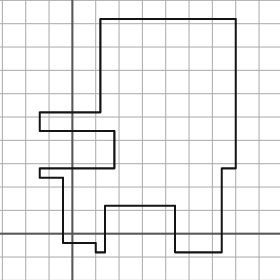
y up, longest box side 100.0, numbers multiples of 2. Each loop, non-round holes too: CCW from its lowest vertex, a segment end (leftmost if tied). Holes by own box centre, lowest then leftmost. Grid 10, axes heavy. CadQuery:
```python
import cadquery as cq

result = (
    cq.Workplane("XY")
    .moveTo(10.0, -8.0)
    .lineTo(14.0, -8.0)
    .lineTo(14.0, 12.0)
    .lineTo(44.0, 12.0)
    .lineTo(44.0, -8.0)
    .lineTo(64.0, -8.0)
    .lineTo(64.0, 28.0)
    .lineTo(70.0, 28.0)
    .lineTo(70.0, 92.0)
    .lineTo(12.0, 92.0)
    .lineTo(12.0, 52.0)
    .lineTo(-14.0, 52.0)
    .lineTo(-14.0, 44.0)
    .lineTo(18.0, 44.0)
    .lineTo(18.0, 28.0)
    .lineTo(-14.0, 28.0)
    .lineTo(-14.0, 24.0)
    .lineTo(-4.0, 24.0)
    .lineTo(-4.0, -4.0)
    .lineTo(10.0, -4.0)
    .close()
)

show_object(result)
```